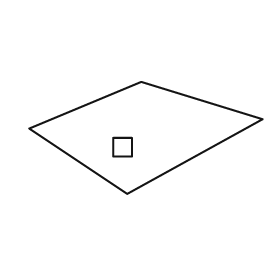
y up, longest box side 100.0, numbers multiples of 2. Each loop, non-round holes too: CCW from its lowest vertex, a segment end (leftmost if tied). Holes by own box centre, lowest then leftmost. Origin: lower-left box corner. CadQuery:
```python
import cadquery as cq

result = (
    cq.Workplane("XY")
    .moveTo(42.0, 0.0)
    .lineTo(100.0, 32.0)
    .lineTo(48.0, 48.0)
    .lineTo(0.0, 28.0)
    .close()
    .moveTo(36.0, 16.0)
    .lineTo(44.0, 16.0)
    .lineTo(44.0, 24.0)
    .lineTo(36.0, 24.0)
    .close()
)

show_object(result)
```